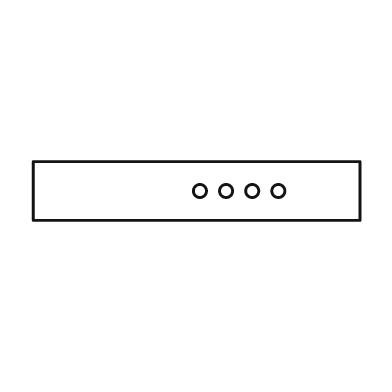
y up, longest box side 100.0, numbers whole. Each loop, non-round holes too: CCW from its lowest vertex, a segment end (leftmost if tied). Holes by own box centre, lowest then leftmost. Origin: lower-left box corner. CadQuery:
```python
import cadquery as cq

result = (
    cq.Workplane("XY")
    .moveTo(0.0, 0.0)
    .lineTo(100.0, 0.0)
    .lineTo(100.0, 18.0)
    .lineTo(0.0, 18.0)
    .close()
    .moveTo(51.0, 9.0)
    .circle(2.0)
    .moveTo(59.0, 9.0)
    .circle(2.0)
    .moveTo(67.0, 9.0)
    .circle(2.0)
    .moveTo(75.0, 9.0)
    .circle(2.0)
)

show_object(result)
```